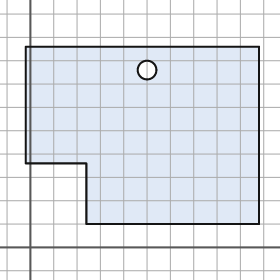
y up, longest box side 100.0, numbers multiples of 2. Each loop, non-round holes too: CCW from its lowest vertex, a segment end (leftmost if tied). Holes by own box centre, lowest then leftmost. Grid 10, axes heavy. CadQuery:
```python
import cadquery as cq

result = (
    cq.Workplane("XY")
    .moveTo(24.0, 10.0)
    .lineTo(98.0, 10.0)
    .lineTo(98.0, 86.0)
    .lineTo(-2.0, 86.0)
    .lineTo(-2.0, 36.0)
    .lineTo(24.0, 36.0)
    .close()
    .moveTo(50.0, 76.0)
    .circle(4.0)
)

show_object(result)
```